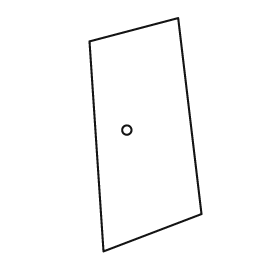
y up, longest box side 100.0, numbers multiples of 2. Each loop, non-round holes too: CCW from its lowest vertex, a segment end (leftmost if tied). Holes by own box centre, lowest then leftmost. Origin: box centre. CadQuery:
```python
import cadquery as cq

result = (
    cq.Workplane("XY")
    .moveTo(-18.0, -50.0)
    .lineTo(24.0, -34.0)
    .lineTo(14.0, 50.0)
    .lineTo(-24.0, 40.0)
    .close()
    .moveTo(-8.0, 2.0)
    .circle(2.0)
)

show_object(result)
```